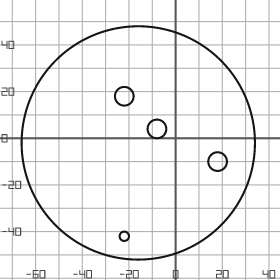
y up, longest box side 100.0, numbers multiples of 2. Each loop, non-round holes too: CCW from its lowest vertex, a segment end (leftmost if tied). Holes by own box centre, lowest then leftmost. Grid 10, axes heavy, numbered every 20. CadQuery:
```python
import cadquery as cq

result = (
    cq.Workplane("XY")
    .moveTo(-16.0, -2.0)
    .circle(50.0)
    .moveTo(-22.0, -42.0)
    .circle(2.0)
    .moveTo(18.0, -10.0)
    .circle(4.0)
    .moveTo(-8.0, 4.0)
    .circle(4.0)
    .moveTo(-22.0, 18.0)
    .circle(4.0)
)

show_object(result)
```